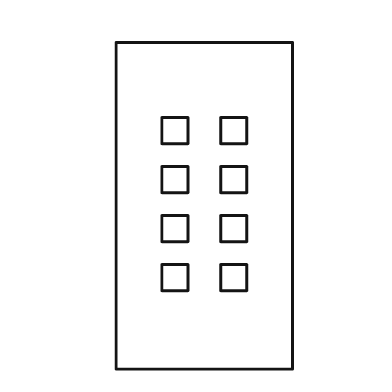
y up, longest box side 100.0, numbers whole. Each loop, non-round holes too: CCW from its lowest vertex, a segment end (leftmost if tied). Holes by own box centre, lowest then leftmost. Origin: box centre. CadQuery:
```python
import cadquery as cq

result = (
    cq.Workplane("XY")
    .moveTo(-27.0, -50.0)
    .lineTo(27.0, -50.0)
    .lineTo(27.0, 50.0)
    .lineTo(-27.0, 50.0)
    .close()
    .moveTo(-13.0, -26.0)
    .lineTo(-5.0, -26.0)
    .lineTo(-5.0, -18.0)
    .lineTo(-13.0, -18.0)
    .close()
    .moveTo(5.0, -26.0)
    .lineTo(13.0, -26.0)
    .lineTo(13.0, -18.0)
    .lineTo(5.0, -18.0)
    .close()
    .moveTo(-13.0, -11.0)
    .lineTo(-5.0, -11.0)
    .lineTo(-5.0, -3.0)
    .lineTo(-13.0, -3.0)
    .close()
    .moveTo(5.0, -11.0)
    .lineTo(13.0, -11.0)
    .lineTo(13.0, -3.0)
    .lineTo(5.0, -3.0)
    .close()
    .moveTo(-13.0, 4.0)
    .lineTo(-5.0, 4.0)
    .lineTo(-5.0, 12.0)
    .lineTo(-13.0, 12.0)
    .close()
    .moveTo(5.0, 4.0)
    .lineTo(13.0, 4.0)
    .lineTo(13.0, 12.0)
    .lineTo(5.0, 12.0)
    .close()
    .moveTo(-13.0, 19.0)
    .lineTo(-5.0, 19.0)
    .lineTo(-5.0, 27.0)
    .lineTo(-13.0, 27.0)
    .close()
    .moveTo(5.0, 19.0)
    .lineTo(13.0, 19.0)
    .lineTo(13.0, 27.0)
    .lineTo(5.0, 27.0)
    .close()
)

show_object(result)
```